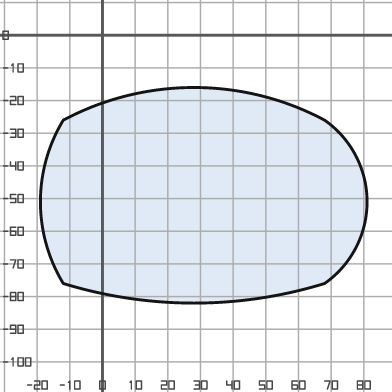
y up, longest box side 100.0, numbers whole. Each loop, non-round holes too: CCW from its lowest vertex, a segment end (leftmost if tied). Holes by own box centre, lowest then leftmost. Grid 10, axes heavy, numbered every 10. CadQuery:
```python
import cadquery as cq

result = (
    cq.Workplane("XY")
    .moveTo(-12.0, -76.0)
    .threePointArc((28.0, -82.0), (68.0, -76.0))
    .threePointArc((81.0, -51.0), (68.0, -26.0))
    .threePointArc((28.0, -16.0), (-12.0, -26.0))
    .threePointArc((-19.0, -51.0), (-12.0, -76.0))
    .close()
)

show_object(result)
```